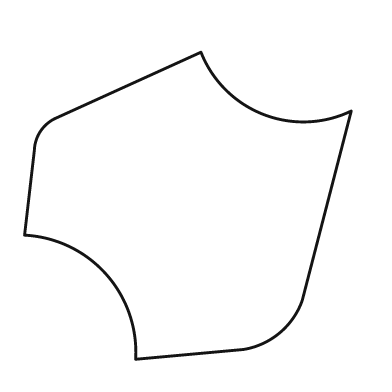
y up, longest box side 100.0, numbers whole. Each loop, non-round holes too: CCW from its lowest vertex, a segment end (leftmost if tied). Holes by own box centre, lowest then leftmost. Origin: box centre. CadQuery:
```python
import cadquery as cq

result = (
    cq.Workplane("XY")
    .moveTo(-16.0, -47.0)
    .lineTo(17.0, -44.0)
    .threePointArc((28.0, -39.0), (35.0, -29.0))
    .lineTo(50.0, 29.0)
    .threePointArc((23.0, 28.0), (4.0, 47.0))
    .lineTo(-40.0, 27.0)
    .threePointArc((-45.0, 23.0), (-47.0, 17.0))
    .lineTo(-50.0, -9.0)
    .threePointArc((-25.0, -21.0), (-16.0, -47.0))
    .close()
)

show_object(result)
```